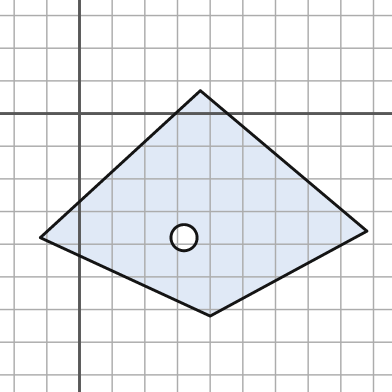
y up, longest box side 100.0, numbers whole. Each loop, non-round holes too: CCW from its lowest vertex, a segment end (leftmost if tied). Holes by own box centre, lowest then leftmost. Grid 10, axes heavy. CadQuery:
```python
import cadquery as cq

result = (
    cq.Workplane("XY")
    .moveTo(40.0, -62.0)
    .lineTo(88.0, -36.0)
    .lineTo(37.0, 7.0)
    .lineTo(-12.0, -38.0)
    .close()
    .moveTo(32.0, -38.0)
    .circle(4.0)
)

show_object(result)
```